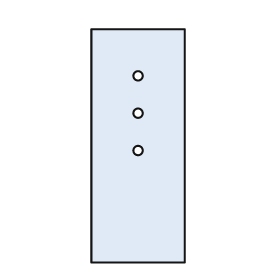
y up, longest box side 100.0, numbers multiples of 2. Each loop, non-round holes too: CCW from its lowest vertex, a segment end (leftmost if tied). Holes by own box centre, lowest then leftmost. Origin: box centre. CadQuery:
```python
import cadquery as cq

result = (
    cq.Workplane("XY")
    .moveTo(-20.0, -50.0)
    .lineTo(20.0, -50.0)
    .lineTo(20.0, 50.0)
    .lineTo(-20.0, 50.0)
    .close()
    .moveTo(0.0, -2.0)
    .circle(2.0)
    .moveTo(0.0, 14.0)
    .circle(2.0)
    .moveTo(0.0, 30.0)
    .circle(2.0)
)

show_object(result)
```